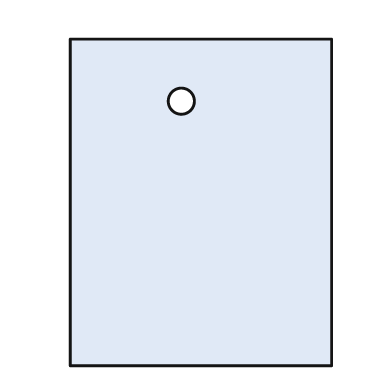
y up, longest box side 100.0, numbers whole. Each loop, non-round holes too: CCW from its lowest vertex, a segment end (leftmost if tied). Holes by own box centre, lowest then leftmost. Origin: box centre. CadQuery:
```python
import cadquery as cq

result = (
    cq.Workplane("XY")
    .moveTo(-40.0, -50.0)
    .lineTo(40.0, -50.0)
    .lineTo(40.0, 50.0)
    .lineTo(-40.0, 50.0)
    .close()
    .moveTo(-6.0, 31.0)
    .circle(4.0)
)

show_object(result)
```